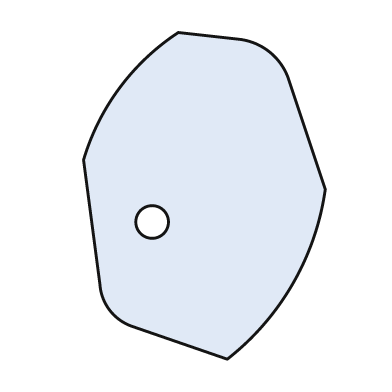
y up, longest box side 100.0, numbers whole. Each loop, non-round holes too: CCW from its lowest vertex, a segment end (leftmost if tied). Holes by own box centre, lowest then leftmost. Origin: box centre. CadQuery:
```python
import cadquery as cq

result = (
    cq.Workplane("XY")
    .moveTo(7.0, -50.0)
    .threePointArc((27.0, -27.0), (37.0, 2.0))
    .lineTo(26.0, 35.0)
    .threePointArc((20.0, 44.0), (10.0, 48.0))
    .lineTo(-8.0, 50.0)
    .threePointArc((-26.0, 33.0), (-37.0, 11.0))
    .lineTo(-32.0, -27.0)
    .threePointArc((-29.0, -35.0), (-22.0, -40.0))
    .close()
    .moveTo(-16.0, -8.0)
    .circle(5.0)
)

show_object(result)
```